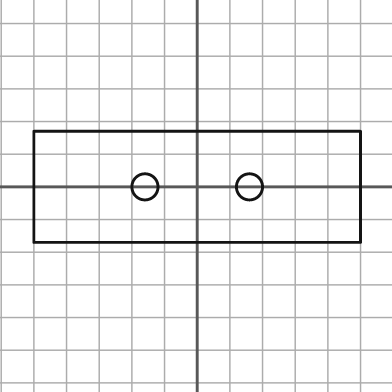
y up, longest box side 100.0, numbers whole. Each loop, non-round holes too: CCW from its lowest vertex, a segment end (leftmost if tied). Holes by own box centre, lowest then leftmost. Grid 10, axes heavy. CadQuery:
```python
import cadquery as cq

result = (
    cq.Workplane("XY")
    .moveTo(-50.0, -17.0)
    .lineTo(50.0, -17.0)
    .lineTo(50.0, 17.0)
    .lineTo(-50.0, 17.0)
    .close()
    .moveTo(-16.0, 0.0)
    .circle(4.0)
    .moveTo(16.0, 0.0)
    .circle(4.0)
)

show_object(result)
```